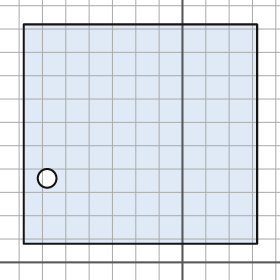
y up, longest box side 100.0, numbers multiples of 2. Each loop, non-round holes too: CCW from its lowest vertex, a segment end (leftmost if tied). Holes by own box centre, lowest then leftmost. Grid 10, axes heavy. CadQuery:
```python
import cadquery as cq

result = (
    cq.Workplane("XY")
    .moveTo(-68.0, 8.0)
    .lineTo(32.0, 8.0)
    .lineTo(32.0, 102.0)
    .lineTo(-68.0, 102.0)
    .close()
    .moveTo(-58.0, 36.0)
    .circle(4.0)
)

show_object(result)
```